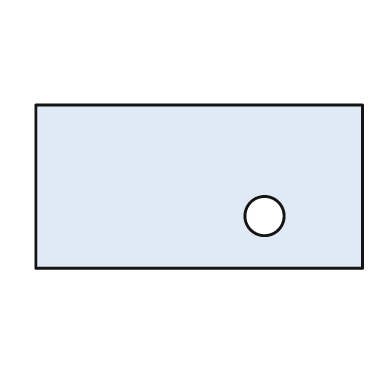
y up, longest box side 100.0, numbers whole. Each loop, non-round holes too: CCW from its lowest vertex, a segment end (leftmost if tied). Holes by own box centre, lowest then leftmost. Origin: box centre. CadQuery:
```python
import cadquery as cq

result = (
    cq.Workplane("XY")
    .moveTo(-50.0, -25.0)
    .lineTo(50.0, -25.0)
    .lineTo(50.0, 25.0)
    .lineTo(-50.0, 25.0)
    .close()
    .moveTo(20.0, -9.0)
    .circle(6.0)
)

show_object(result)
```